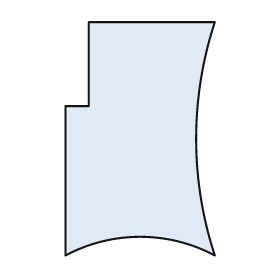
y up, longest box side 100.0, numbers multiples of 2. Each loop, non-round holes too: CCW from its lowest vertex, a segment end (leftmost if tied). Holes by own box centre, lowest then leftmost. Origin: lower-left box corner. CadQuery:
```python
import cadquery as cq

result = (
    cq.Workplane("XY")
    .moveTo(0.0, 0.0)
    .threePointArc((32.0, 8.0), (64.0, 0.0))
    .threePointArc((56.0, 50.0), (64.0, 100.0))
    .lineTo(10.0, 100.0)
    .lineTo(10.0, 64.0)
    .lineTo(0.0, 64.0)
    .close()
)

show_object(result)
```